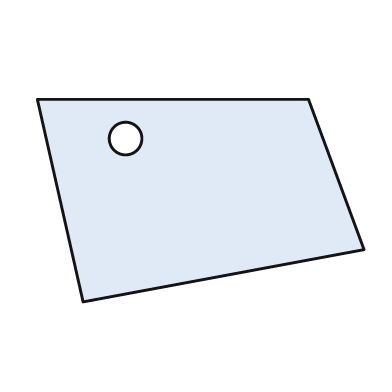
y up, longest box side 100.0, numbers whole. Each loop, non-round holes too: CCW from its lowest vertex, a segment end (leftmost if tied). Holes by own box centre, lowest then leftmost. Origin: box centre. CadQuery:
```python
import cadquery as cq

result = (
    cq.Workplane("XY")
    .moveTo(-36.0, -31.0)
    .lineTo(50.0, -15.0)
    .lineTo(33.0, 31.0)
    .lineTo(-50.0, 31.0)
    .close()
    .moveTo(-23.0, 19.0)
    .circle(5.0)
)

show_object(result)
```